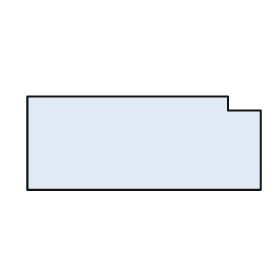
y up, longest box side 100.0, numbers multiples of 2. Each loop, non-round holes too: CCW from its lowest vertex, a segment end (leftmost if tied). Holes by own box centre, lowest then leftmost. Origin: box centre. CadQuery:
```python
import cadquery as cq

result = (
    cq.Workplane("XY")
    .moveTo(-50.0, -20.0)
    .lineTo(50.0, -20.0)
    .lineTo(50.0, 14.0)
    .lineTo(36.0, 14.0)
    .lineTo(36.0, 20.0)
    .lineTo(-50.0, 20.0)
    .close()
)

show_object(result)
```